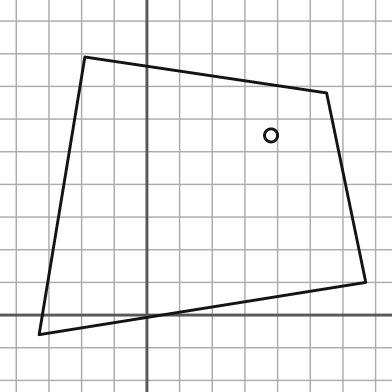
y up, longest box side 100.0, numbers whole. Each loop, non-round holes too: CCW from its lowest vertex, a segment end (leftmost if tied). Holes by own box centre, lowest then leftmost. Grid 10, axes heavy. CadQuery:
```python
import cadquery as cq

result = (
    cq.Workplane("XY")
    .moveTo(-33.0, -6.0)
    .lineTo(67.0, 10.0)
    .lineTo(55.0, 68.0)
    .lineTo(-19.0, 79.0)
    .close()
    .moveTo(38.0, 55.0)
    .circle(2.0)
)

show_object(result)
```